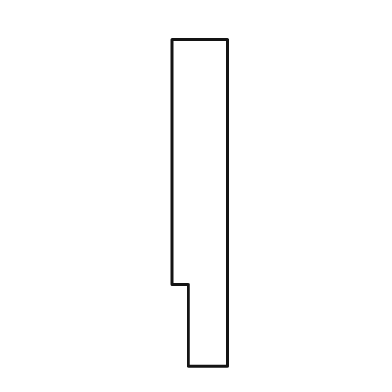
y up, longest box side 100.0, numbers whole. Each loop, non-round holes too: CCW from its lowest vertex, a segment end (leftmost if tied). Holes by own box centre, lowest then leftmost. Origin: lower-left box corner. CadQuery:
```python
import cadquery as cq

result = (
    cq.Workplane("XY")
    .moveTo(5.0, 0.0)
    .lineTo(17.0, 0.0)
    .lineTo(17.0, 100.0)
    .lineTo(0.0, 100.0)
    .lineTo(0.0, 25.0)
    .lineTo(5.0, 25.0)
    .close()
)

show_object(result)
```